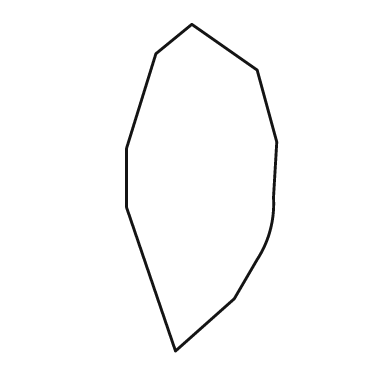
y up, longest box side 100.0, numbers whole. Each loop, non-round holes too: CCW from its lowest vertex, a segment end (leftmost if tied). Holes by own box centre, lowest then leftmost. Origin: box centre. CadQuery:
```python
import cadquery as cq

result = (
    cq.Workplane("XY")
    .moveTo(-8.0, -50.0)
    .lineTo(10.0, -34.0)
    .lineTo(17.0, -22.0)
    .threePointArc((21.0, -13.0), (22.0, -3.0))
    .lineTo(23.0, 14.0)
    .lineTo(17.0, 36.0)
    .lineTo(-3.0, 50.0)
    .lineTo(-14.0, 41.0)
    .lineTo(-23.0, 12.0)
    .lineTo(-23.0, -6.0)
    .close()
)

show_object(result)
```